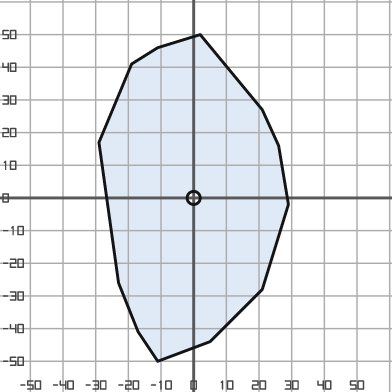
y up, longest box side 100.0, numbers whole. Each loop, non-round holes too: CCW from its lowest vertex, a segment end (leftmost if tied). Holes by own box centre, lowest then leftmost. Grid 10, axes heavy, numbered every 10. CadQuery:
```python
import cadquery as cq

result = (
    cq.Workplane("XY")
    .moveTo(-11.0, -50.0)
    .lineTo(5.0, -44.0)
    .lineTo(21.0, -28.0)
    .lineTo(29.0, -2.0)
    .lineTo(26.0, 16.0)
    .lineTo(21.0, 27.0)
    .lineTo(2.0, 50.0)
    .lineTo(-11.0, 46.0)
    .lineTo(-19.0, 41.0)
    .lineTo(-29.0, 17.0)
    .lineTo(-23.0, -26.0)
    .lineTo(-17.0, -41.0)
    .close()
    .moveTo(0.0, 0.0)
    .circle(2.0)
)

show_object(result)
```